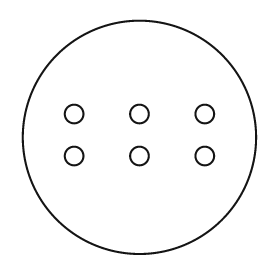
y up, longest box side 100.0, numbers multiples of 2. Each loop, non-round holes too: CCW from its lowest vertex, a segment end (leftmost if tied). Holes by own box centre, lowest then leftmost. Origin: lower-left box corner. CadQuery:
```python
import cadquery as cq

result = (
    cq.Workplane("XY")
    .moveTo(50.0, 50.0)
    .circle(50.0)
    .moveTo(22.0, 42.0)
    .circle(4.0)
    .moveTo(50.0, 42.0)
    .circle(4.0)
    .moveTo(78.0, 42.0)
    .circle(4.0)
    .moveTo(22.0, 60.0)
    .circle(4.0)
    .moveTo(50.0, 60.0)
    .circle(4.0)
    .moveTo(78.0, 60.0)
    .circle(4.0)
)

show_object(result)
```